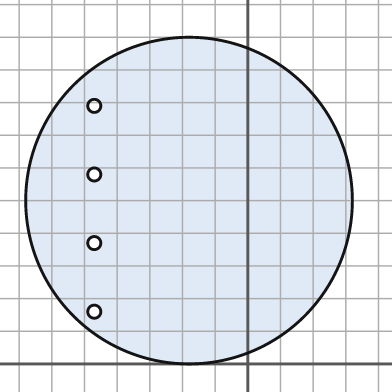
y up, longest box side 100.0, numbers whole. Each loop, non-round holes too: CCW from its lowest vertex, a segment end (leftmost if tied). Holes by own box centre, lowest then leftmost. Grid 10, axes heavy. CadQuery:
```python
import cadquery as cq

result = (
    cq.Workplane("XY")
    .moveTo(-18.0, 50.0)
    .circle(50.0)
    .moveTo(-47.0, 16.0)
    .circle(2.0)
    .moveTo(-47.0, 37.0)
    .circle(2.0)
    .moveTo(-47.0, 58.0)
    .circle(2.0)
    .moveTo(-47.0, 79.0)
    .circle(2.0)
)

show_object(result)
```